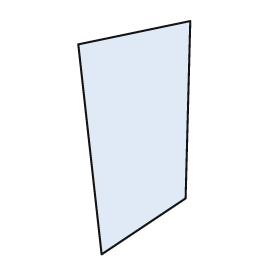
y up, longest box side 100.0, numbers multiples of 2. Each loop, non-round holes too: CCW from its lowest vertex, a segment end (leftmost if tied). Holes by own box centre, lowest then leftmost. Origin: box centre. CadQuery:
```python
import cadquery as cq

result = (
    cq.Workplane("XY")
    .moveTo(-14.0, -50.0)
    .lineTo(22.0, -26.0)
    .lineTo(24.0, 50.0)
    .lineTo(-24.0, 40.0)
    .close()
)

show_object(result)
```